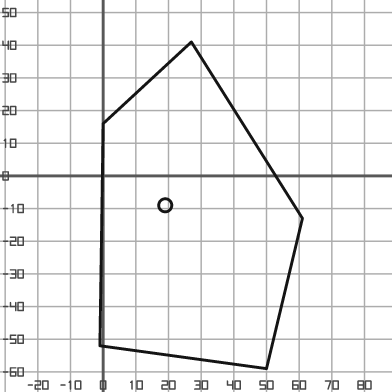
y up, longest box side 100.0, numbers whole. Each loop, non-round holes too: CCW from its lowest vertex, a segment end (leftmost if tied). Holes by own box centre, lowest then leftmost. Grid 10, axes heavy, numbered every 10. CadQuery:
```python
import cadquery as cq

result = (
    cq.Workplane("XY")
    .moveTo(50.0, -59.0)
    .lineTo(61.0, -13.0)
    .lineTo(27.0, 41.0)
    .lineTo(0.0, 16.0)
    .lineTo(-1.0, -52.0)
    .close()
    .moveTo(19.0, -9.0)
    .circle(2.0)
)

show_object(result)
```